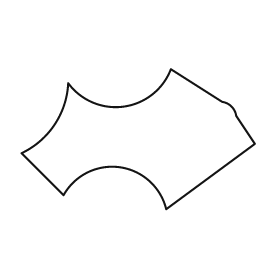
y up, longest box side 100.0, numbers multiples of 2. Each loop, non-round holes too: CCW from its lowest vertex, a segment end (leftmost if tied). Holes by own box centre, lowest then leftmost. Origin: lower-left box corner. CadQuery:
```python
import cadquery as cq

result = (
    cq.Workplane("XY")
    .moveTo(62.0, 0.0)
    .lineTo(100.0, 28.0)
    .lineTo(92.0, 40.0)
    .threePointArc((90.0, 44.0), (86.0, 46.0))
    .lineTo(64.0, 60.0)
    .threePointArc((44.0, 44.0), (20.0, 54.0))
    .threePointArc((14.0, 36.0), (0.0, 24.0))
    .lineTo(18.0, 6.0)
    .threePointArc((42.0, 18.0), (62.0, 0.0))
    .close()
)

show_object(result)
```